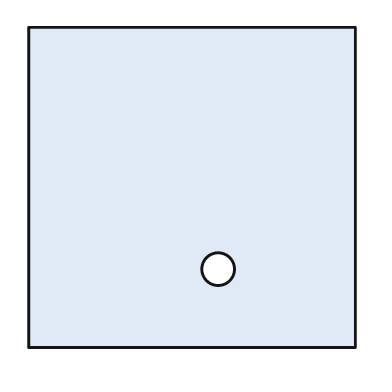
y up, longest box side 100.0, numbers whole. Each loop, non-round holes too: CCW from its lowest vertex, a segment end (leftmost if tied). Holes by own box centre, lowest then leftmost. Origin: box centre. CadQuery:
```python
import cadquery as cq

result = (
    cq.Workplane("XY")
    .moveTo(-50.0, -49.0)
    .lineTo(50.0, -49.0)
    .lineTo(50.0, 49.0)
    .lineTo(-50.0, 49.0)
    .close()
    .moveTo(8.0, -25.0)
    .circle(5.0)
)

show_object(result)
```